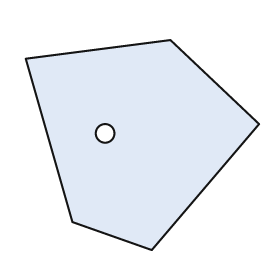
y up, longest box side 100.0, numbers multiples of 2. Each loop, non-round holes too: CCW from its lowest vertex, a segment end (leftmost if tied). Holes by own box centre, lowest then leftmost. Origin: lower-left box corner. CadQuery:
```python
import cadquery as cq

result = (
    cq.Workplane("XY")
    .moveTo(54.0, 0.0)
    .lineTo(100.0, 54.0)
    .lineTo(62.0, 90.0)
    .lineTo(0.0, 82.0)
    .lineTo(20.0, 12.0)
    .close()
    .moveTo(34.0, 50.0)
    .circle(4.0)
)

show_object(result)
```